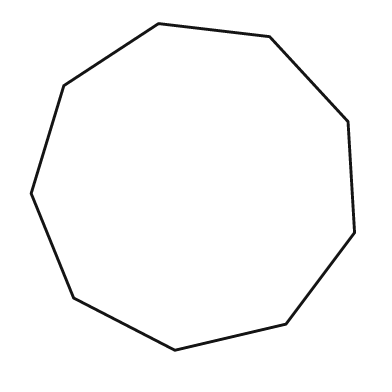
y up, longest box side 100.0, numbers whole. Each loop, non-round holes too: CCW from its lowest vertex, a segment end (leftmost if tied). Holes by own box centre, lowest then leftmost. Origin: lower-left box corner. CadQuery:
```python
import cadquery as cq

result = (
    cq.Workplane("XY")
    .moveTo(44.0, 0.0)
    .lineTo(78.0, 8.0)
    .lineTo(99.0, 36.0)
    .lineTo(97.0, 70.0)
    .lineTo(73.0, 96.0)
    .lineTo(39.0, 100.0)
    .lineTo(10.0, 81.0)
    .lineTo(0.0, 48.0)
    .lineTo(13.0, 16.0)
    .close()
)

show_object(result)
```